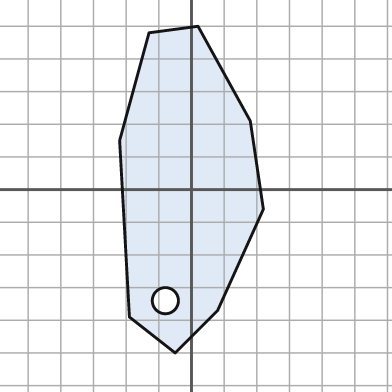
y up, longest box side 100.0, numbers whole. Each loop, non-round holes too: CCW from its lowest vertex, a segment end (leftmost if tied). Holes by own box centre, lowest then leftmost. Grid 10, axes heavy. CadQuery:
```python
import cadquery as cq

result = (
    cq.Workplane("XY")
    .moveTo(-5.0, -50.0)
    .lineTo(8.0, -37.0)
    .lineTo(22.0, -6.0)
    .lineTo(18.0, 21.0)
    .lineTo(2.0, 50.0)
    .lineTo(-13.0, 48.0)
    .lineTo(-22.0, 15.0)
    .lineTo(-19.0, -39.0)
    .close()
    .moveTo(-8.0, -34.0)
    .circle(4.0)
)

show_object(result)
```